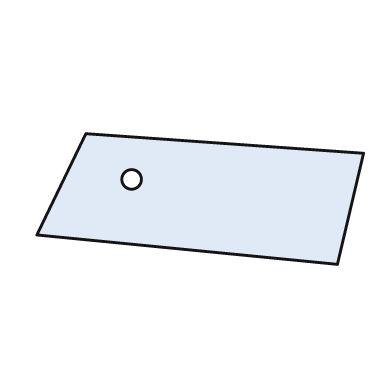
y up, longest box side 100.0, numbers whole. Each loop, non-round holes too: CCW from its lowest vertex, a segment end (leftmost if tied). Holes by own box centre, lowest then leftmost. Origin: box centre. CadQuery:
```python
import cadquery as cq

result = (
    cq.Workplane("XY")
    .moveTo(42.0, -20.0)
    .lineTo(50.0, 14.0)
    .lineTo(-35.0, 20.0)
    .lineTo(-50.0, -11.0)
    .close()
    .moveTo(-21.0, 6.0)
    .circle(3.0)
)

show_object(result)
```